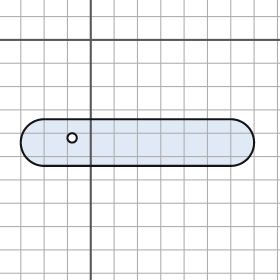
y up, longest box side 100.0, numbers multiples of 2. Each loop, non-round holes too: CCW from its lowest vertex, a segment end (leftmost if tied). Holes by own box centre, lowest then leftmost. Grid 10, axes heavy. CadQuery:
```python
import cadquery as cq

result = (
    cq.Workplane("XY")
    .moveTo(-20.0, -54.0)
    .lineTo(60.0, -54.0)
    .threePointArc((70.0, -44.0), (60.0, -34.0))
    .lineTo(-20.0, -34.0)
    .threePointArc((-30.0, -44.0), (-20.0, -54.0))
    .close()
    .moveTo(-8.0, -42.0)
    .circle(2.0)
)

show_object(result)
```